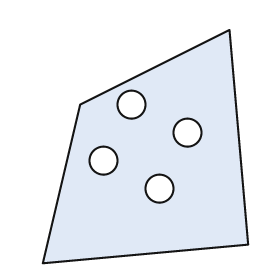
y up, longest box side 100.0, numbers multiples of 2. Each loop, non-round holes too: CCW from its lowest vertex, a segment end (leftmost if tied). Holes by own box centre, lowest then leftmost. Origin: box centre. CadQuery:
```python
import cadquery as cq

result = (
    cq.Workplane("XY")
    .moveTo(-44.0, -50.0)
    .lineTo(44.0, -42.0)
    .lineTo(36.0, 50.0)
    .lineTo(-28.0, 18.0)
    .close()
    .moveTo(6.0, -18.0)
    .circle(6.0)
    .moveTo(-18.0, -6.0)
    .circle(6.0)
    .moveTo(18.0, 6.0)
    .circle(6.0)
    .moveTo(-6.0, 18.0)
    .circle(6.0)
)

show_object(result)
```